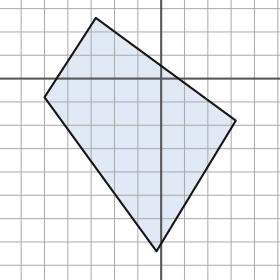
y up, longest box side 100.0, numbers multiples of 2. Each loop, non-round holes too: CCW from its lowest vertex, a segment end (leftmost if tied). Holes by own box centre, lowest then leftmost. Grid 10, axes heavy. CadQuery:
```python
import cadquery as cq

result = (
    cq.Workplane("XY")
    .moveTo(-2.0, -74.0)
    .lineTo(32.0, -18.0)
    .lineTo(-28.0, 26.0)
    .lineTo(-50.0, -8.0)
    .close()
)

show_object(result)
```